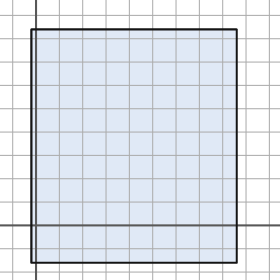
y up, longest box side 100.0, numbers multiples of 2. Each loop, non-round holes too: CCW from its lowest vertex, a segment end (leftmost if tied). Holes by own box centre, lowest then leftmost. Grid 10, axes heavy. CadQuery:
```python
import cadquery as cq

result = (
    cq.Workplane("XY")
    .moveTo(-2.0, -16.0)
    .lineTo(86.0, -16.0)
    .lineTo(86.0, 84.0)
    .lineTo(-2.0, 84.0)
    .close()
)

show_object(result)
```